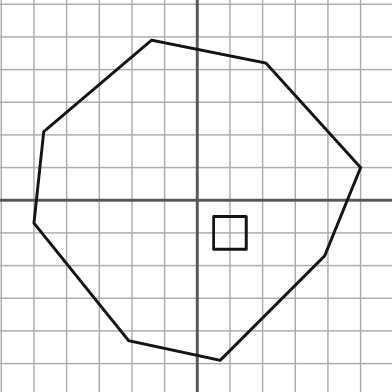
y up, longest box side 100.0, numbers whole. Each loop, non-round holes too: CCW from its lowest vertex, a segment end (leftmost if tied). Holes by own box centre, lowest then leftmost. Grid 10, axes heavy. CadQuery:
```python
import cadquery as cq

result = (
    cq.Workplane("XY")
    .moveTo(7.0, -49.0)
    .lineTo(39.0, -17.0)
    .lineTo(50.0, 10.0)
    .lineTo(21.0, 42.0)
    .lineTo(-14.0, 49.0)
    .lineTo(-47.0, 21.0)
    .lineTo(-50.0, -7.0)
    .lineTo(-21.0, -43.0)
    .close()
    .moveTo(5.0, -15.0)
    .lineTo(15.0, -15.0)
    .lineTo(15.0, -5.0)
    .lineTo(5.0, -5.0)
    .close()
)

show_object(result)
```